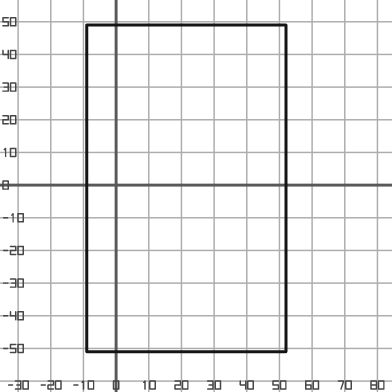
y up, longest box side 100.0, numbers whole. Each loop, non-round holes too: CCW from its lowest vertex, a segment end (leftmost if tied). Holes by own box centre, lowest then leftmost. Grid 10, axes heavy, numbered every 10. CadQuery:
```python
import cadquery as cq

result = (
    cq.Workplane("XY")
    .moveTo(-9.0, -51.0)
    .lineTo(52.0, -51.0)
    .lineTo(52.0, 49.0)
    .lineTo(-9.0, 49.0)
    .close()
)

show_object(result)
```